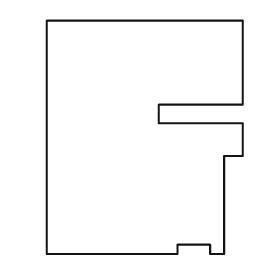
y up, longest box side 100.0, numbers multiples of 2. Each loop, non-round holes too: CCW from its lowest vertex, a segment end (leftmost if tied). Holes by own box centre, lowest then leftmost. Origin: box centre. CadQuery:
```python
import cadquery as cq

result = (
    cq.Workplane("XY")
    .moveTo(-42.0, -50.0)
    .lineTo(14.0, -50.0)
    .lineTo(14.0, -46.0)
    .lineTo(28.0, -46.0)
    .lineTo(28.0, -50.0)
    .lineTo(34.0, -50.0)
    .lineTo(34.0, -8.0)
    .lineTo(42.0, -8.0)
    .lineTo(42.0, 6.0)
    .lineTo(6.0, 6.0)
    .lineTo(6.0, 14.0)
    .lineTo(42.0, 14.0)
    .lineTo(42.0, 50.0)
    .lineTo(-42.0, 50.0)
    .close()
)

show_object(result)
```